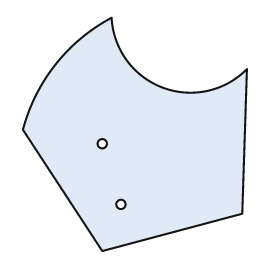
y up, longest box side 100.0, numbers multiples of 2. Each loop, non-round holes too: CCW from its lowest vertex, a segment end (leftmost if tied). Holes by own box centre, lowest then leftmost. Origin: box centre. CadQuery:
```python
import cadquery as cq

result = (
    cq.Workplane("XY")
    .moveTo(-14.0, -50.0)
    .lineTo(46.0, -34.0)
    .lineTo(48.0, 28.0)
    .threePointArc((12.0, 20.0), (-10.0, 50.0))
    .threePointArc((-34.0, 30.0), (-48.0, 2.0))
    .close()
    .moveTo(-6.0, -30.0)
    .circle(2.0)
    .moveTo(-14.0, -4.0)
    .circle(2.0)
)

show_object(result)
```